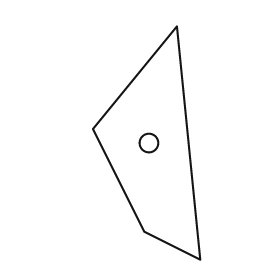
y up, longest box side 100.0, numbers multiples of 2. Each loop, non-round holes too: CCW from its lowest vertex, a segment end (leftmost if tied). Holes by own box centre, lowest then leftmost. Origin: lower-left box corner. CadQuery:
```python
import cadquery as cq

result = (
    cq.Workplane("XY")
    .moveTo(46.0, 0.0)
    .lineTo(36.0, 100.0)
    .lineTo(0.0, 56.0)
    .lineTo(22.0, 12.0)
    .close()
    .moveTo(24.0, 50.0)
    .circle(4.0)
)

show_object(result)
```